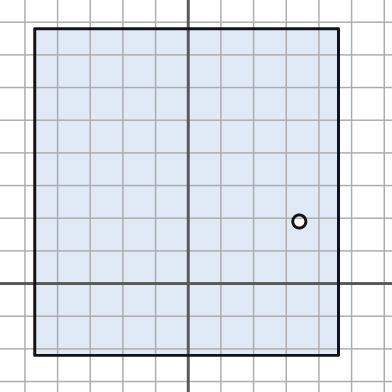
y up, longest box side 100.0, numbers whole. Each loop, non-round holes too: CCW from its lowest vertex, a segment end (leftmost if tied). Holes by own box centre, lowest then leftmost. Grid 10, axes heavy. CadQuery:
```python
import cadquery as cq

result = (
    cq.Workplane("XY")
    .moveTo(-47.0, -22.0)
    .lineTo(46.0, -22.0)
    .lineTo(46.0, 78.0)
    .lineTo(-47.0, 78.0)
    .close()
    .moveTo(34.0, 19.0)
    .circle(2.0)
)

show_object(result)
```